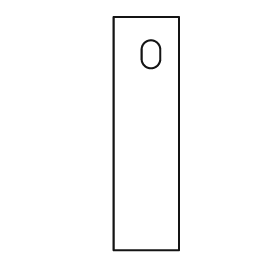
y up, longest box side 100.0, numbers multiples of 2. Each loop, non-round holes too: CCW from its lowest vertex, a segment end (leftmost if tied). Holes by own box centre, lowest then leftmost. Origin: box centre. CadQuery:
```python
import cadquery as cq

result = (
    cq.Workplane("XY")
    .moveTo(-14.0, -50.0)
    .lineTo(14.0, -50.0)
    .lineTo(14.0, 50.0)
    .lineTo(-14.0, 50.0)
    .close()
    .moveTo(-2.0, 32.0)
    .threePointArc((2.0, 28.0), (6.0, 32.0))
    .lineTo(6.0, 36.0)
    .threePointArc((2.0, 40.0), (-2.0, 36.0))
    .close()
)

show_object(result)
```